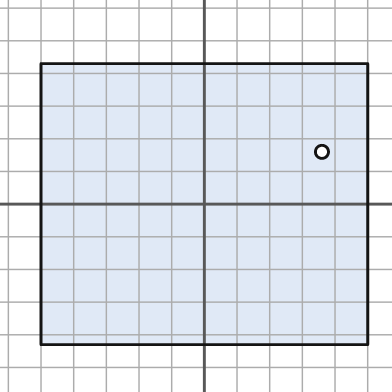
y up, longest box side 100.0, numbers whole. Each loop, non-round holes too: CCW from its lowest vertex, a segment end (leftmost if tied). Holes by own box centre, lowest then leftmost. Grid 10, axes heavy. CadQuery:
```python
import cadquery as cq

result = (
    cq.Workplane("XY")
    .moveTo(-50.0, -43.0)
    .lineTo(50.0, -43.0)
    .lineTo(50.0, 43.0)
    .lineTo(-50.0, 43.0)
    .close()
    .moveTo(36.0, 16.0)
    .circle(2.0)
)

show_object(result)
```